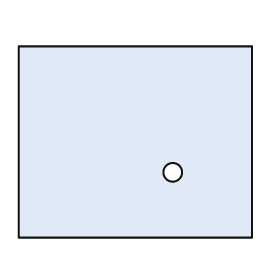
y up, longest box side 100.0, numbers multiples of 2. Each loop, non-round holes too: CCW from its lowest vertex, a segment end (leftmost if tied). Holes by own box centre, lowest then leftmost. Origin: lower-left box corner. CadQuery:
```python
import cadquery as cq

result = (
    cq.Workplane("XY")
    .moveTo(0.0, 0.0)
    .lineTo(100.0, 0.0)
    .lineTo(100.0, 82.0)
    .lineTo(0.0, 82.0)
    .close()
    .moveTo(66.0, 28.0)
    .circle(4.0)
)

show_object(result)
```